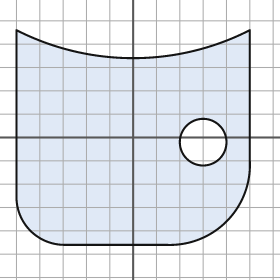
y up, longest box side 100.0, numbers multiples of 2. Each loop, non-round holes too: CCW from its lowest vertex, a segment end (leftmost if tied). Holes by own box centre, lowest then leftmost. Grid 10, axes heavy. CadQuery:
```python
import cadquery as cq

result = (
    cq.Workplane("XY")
    .moveTo(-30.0, -46.0)
    .lineTo(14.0, -46.0)
    .threePointArc((40.0, -36.0), (50.0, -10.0))
    .lineTo(50.0, 46.0)
    .threePointArc((0.0, 34.0), (-50.0, 46.0))
    .lineTo(-50.0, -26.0)
    .threePointArc((-44.0, -40.0), (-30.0, -46.0))
    .close()
    .moveTo(30.0, -2.0)
    .circle(10.0)
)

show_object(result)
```